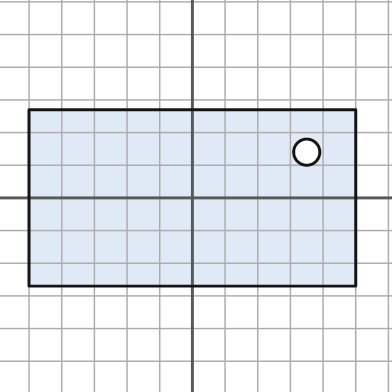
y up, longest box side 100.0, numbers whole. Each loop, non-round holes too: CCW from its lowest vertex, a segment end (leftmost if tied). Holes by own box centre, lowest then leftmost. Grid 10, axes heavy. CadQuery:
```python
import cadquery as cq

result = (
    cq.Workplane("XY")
    .moveTo(-50.0, -27.0)
    .lineTo(50.0, -27.0)
    .lineTo(50.0, 27.0)
    .lineTo(-50.0, 27.0)
    .close()
    .moveTo(35.0, 14.0)
    .circle(4.0)
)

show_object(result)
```